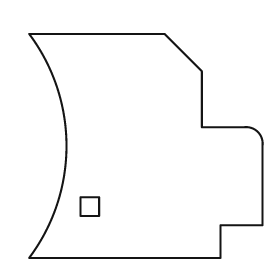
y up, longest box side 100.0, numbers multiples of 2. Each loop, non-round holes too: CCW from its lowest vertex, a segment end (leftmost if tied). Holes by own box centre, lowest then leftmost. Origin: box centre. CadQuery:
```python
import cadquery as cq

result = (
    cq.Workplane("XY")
    .moveTo(-50.0, -48.0)
    .lineTo(32.0, -48.0)
    .lineTo(32.0, -34.0)
    .lineTo(50.0, -34.0)
    .lineTo(50.0, 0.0)
    .threePointArc((48.0, 6.0), (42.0, 8.0))
    .lineTo(24.0, 8.0)
    .lineTo(24.0, 32.0)
    .lineTo(8.0, 48.0)
    .lineTo(-50.0, 48.0)
    .threePointArc((-34.0, 0.0), (-50.0, -48.0))
    .close()
    .moveTo(-28.0, -30.0)
    .lineTo(-20.0, -30.0)
    .lineTo(-20.0, -22.0)
    .lineTo(-28.0, -22.0)
    .close()
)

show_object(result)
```